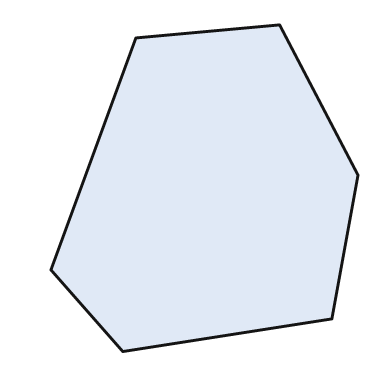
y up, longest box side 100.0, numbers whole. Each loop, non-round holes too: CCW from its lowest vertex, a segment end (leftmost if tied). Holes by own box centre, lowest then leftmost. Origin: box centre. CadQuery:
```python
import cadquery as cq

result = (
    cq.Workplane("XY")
    .moveTo(-25.0, -50.0)
    .lineTo(39.0, -40.0)
    .lineTo(47.0, 4.0)
    .lineTo(23.0, 50.0)
    .lineTo(-21.0, 46.0)
    .lineTo(-47.0, -25.0)
    .close()
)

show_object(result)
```